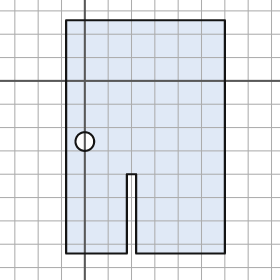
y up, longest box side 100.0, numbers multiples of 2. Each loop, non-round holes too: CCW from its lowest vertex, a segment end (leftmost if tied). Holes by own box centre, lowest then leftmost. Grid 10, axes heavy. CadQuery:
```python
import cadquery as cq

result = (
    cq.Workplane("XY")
    .moveTo(-8.0, -74.0)
    .lineTo(18.0, -74.0)
    .lineTo(18.0, -40.0)
    .lineTo(22.0, -40.0)
    .lineTo(22.0, -74.0)
    .lineTo(60.0, -74.0)
    .lineTo(60.0, 26.0)
    .lineTo(-8.0, 26.0)
    .close()
    .moveTo(0.0, -26.0)
    .circle(4.0)
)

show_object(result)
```